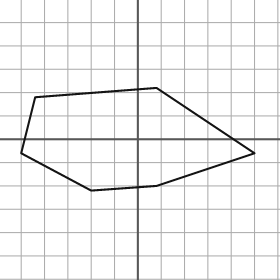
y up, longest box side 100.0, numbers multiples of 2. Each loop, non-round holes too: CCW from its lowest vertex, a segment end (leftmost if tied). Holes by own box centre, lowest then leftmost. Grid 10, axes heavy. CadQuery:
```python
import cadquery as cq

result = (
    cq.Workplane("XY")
    .moveTo(-20.0, -22.0)
    .lineTo(8.0, -20.0)
    .lineTo(50.0, -6.0)
    .lineTo(8.0, 22.0)
    .lineTo(-44.0, 18.0)
    .lineTo(-50.0, -6.0)
    .close()
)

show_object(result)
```